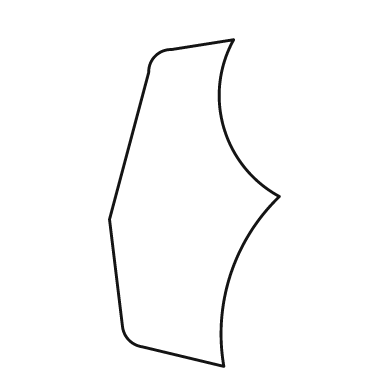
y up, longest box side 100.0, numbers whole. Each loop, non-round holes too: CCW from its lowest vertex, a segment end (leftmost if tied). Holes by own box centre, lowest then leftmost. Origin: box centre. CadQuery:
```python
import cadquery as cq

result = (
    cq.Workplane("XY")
    .moveTo(9.0, -50.0)
    .threePointArc((11.0, -22.0), (26.0, 2.0))
    .threePointArc((9.0, 23.0), (12.0, 50.0))
    .lineTo(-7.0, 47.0)
    .threePointArc((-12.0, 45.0), (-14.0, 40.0))
    .lineTo(-26.0, -5.0)
    .lineTo(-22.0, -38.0)
    .threePointArc((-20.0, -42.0), (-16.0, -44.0))
    .close()
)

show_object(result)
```